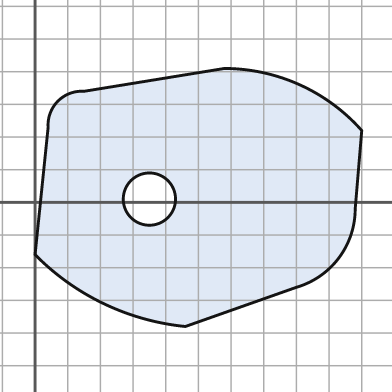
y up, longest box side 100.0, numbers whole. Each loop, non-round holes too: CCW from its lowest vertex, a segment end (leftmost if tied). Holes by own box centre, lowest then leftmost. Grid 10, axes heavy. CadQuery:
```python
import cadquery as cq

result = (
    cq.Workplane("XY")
    .moveTo(46.0, -38.0)
    .lineTo(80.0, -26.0)
    .threePointArc((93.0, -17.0), (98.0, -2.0))
    .lineTo(100.0, 22.0)
    .threePointArc((81.0, 36.0), (58.0, 41.0))
    .lineTo(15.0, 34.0)
    .threePointArc((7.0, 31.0), (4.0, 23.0))
    .lineTo(0.0, -16.0)
    .threePointArc((21.0, -31.0), (46.0, -38.0))
    .close()
    .moveTo(35.0, 1.0)
    .circle(8.0)
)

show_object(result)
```